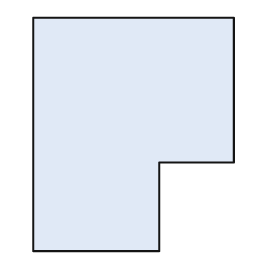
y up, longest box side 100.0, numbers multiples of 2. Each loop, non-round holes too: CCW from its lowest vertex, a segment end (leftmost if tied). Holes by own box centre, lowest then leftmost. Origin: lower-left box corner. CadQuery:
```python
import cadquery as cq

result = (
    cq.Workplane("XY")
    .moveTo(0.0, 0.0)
    .lineTo(54.0, 0.0)
    .lineTo(54.0, 38.0)
    .lineTo(86.0, 38.0)
    .lineTo(86.0, 100.0)
    .lineTo(0.0, 100.0)
    .close()
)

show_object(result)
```